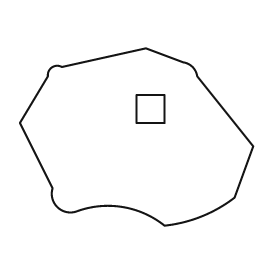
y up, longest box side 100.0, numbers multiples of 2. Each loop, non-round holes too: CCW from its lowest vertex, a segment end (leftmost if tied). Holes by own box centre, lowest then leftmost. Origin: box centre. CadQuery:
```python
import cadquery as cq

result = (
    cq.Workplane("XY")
    .moveTo(12.0, -38.0)
    .threePointArc((28.0, -34.0), (42.0, -26.0))
    .lineTo(50.0, -4.0)
    .lineTo(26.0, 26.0)
    .threePointArc((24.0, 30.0), (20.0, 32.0))
    .lineTo(4.0, 38.0)
    .lineTo(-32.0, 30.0)
    .threePointArc((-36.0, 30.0), (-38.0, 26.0))
    .lineTo(-50.0, 6.0)
    .lineTo(-36.0, -22.0)
    .threePointArc((-34.0, -30.0), (-26.0, -32.0))
    .threePointArc((-6.0, -30.0), (12.0, -38.0))
    .close()
    .moveTo(0.0, 6.0)
    .lineTo(12.0, 6.0)
    .lineTo(12.0, 18.0)
    .lineTo(0.0, 18.0)
    .close()
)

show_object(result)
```